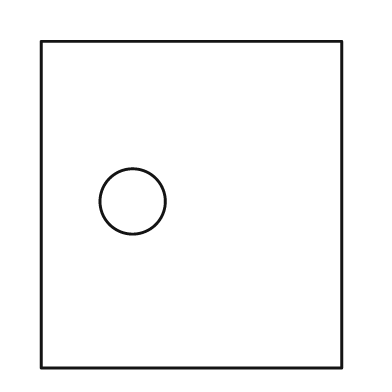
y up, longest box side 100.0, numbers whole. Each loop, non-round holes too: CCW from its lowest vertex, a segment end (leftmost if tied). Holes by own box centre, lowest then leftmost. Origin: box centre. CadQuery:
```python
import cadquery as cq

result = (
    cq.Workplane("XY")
    .moveTo(-46.0, -50.0)
    .lineTo(46.0, -50.0)
    .lineTo(46.0, 50.0)
    .lineTo(-46.0, 50.0)
    .close()
    .moveTo(-18.0, 1.0)
    .circle(10.0)
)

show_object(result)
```